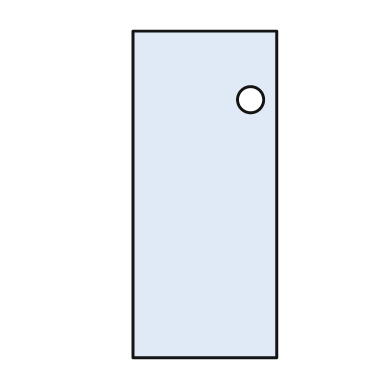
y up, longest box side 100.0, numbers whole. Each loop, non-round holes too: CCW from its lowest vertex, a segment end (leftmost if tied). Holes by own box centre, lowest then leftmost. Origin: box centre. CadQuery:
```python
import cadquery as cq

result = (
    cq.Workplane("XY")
    .moveTo(-22.0, -50.0)
    .lineTo(22.0, -50.0)
    .lineTo(22.0, 50.0)
    .lineTo(-22.0, 50.0)
    .close()
    .moveTo(14.0, 29.0)
    .circle(4.0)
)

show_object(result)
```